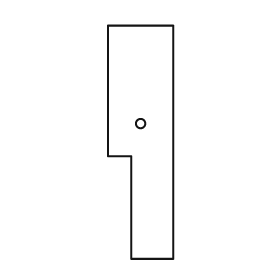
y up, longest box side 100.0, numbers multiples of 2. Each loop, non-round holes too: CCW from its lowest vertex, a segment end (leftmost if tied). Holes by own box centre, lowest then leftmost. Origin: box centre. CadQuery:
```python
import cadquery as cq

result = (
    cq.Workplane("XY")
    .moveTo(-4.0, -50.0)
    .lineTo(14.0, -50.0)
    .lineTo(14.0, 50.0)
    .lineTo(-14.0, 50.0)
    .lineTo(-14.0, -6.0)
    .lineTo(-4.0, -6.0)
    .close()
    .moveTo(0.0, 8.0)
    .circle(2.0)
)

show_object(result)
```